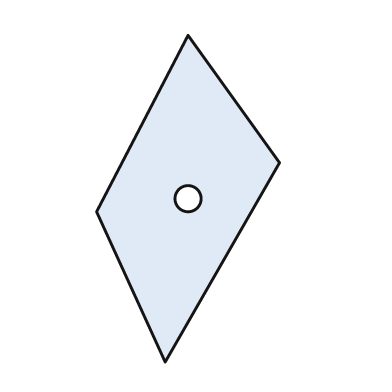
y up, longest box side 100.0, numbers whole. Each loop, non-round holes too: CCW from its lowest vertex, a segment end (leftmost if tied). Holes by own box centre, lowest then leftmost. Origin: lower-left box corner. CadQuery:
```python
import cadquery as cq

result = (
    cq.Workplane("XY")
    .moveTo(21.0, 0.0)
    .lineTo(56.0, 61.0)
    .lineTo(28.0, 100.0)
    .lineTo(0.0, 46.0)
    .close()
    .moveTo(28.0, 50.0)
    .circle(4.0)
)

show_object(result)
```